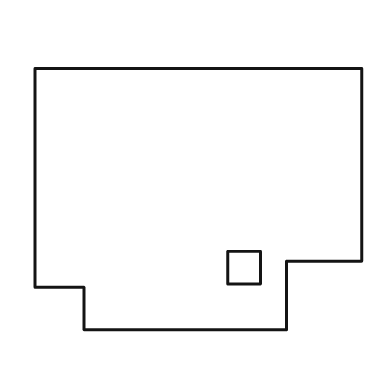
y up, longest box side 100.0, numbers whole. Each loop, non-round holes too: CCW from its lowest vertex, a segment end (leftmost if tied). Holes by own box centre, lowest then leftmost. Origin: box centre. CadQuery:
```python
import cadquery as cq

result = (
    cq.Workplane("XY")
    .moveTo(-35.0, -40.0)
    .lineTo(27.0, -40.0)
    .lineTo(27.0, -19.0)
    .lineTo(50.0, -19.0)
    .lineTo(50.0, 40.0)
    .lineTo(-50.0, 40.0)
    .lineTo(-50.0, -27.0)
    .lineTo(-35.0, -27.0)
    .close()
    .moveTo(9.0, -26.0)
    .lineTo(19.0, -26.0)
    .lineTo(19.0, -16.0)
    .lineTo(9.0, -16.0)
    .close()
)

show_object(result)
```